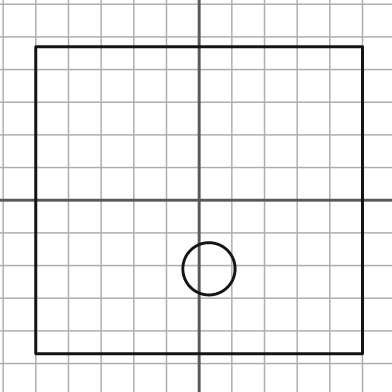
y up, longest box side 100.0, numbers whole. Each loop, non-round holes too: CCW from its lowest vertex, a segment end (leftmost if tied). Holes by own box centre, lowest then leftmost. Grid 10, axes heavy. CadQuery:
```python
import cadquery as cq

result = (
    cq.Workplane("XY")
    .moveTo(-50.0, -47.0)
    .lineTo(50.0, -47.0)
    .lineTo(50.0, 47.0)
    .lineTo(-50.0, 47.0)
    .close()
    .moveTo(3.0, -21.0)
    .circle(8.0)
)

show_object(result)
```